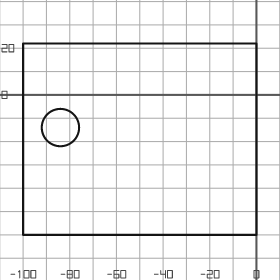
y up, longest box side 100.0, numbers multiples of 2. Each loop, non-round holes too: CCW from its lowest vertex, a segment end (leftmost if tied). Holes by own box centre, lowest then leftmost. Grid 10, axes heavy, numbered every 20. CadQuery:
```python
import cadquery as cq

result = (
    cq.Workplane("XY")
    .moveTo(-100.0, -60.0)
    .lineTo(0.0, -60.0)
    .lineTo(0.0, 22.0)
    .lineTo(-100.0, 22.0)
    .close()
    .moveTo(-84.0, -14.0)
    .circle(8.0)
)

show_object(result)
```